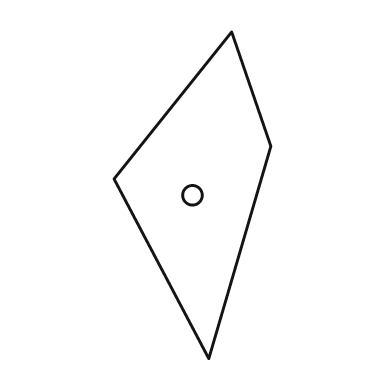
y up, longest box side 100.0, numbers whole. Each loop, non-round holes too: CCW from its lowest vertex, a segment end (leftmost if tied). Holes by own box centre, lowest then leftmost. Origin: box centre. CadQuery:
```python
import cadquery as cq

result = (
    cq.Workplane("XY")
    .moveTo(5.0, -50.0)
    .lineTo(24.0, 15.0)
    .lineTo(12.0, 50.0)
    .lineTo(-24.0, 5.0)
    .close()
    .moveTo(0.0, 0.0)
    .circle(3.0)
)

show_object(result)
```